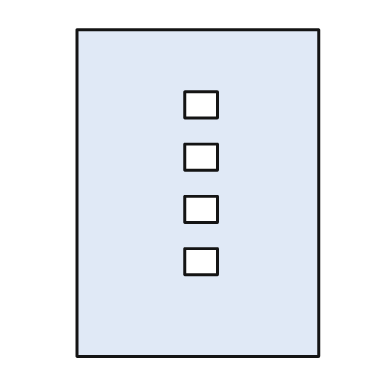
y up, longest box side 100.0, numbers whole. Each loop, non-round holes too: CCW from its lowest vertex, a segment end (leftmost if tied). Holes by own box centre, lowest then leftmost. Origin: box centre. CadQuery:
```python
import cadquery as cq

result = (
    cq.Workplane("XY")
    .moveTo(-37.0, -50.0)
    .lineTo(37.0, -50.0)
    .lineTo(37.0, 50.0)
    .lineTo(-37.0, 50.0)
    .close()
    .moveTo(-4.0, -25.0)
    .lineTo(6.0, -25.0)
    .lineTo(6.0, -17.0)
    .lineTo(-4.0, -17.0)
    .close()
    .moveTo(-4.0, -9.0)
    .lineTo(6.0, -9.0)
    .lineTo(6.0, -1.0)
    .lineTo(-4.0, -1.0)
    .close()
    .moveTo(-4.0, 7.0)
    .lineTo(6.0, 7.0)
    .lineTo(6.0, 15.0)
    .lineTo(-4.0, 15.0)
    .close()
    .moveTo(-4.0, 23.0)
    .lineTo(6.0, 23.0)
    .lineTo(6.0, 31.0)
    .lineTo(-4.0, 31.0)
    .close()
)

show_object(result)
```